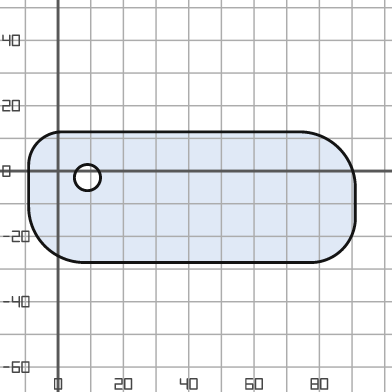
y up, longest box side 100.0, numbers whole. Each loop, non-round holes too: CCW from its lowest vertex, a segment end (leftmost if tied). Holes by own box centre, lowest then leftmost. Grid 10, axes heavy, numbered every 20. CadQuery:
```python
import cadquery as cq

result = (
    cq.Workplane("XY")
    .moveTo(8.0, -28.0)
    .lineTo(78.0, -28.0)
    .threePointArc((87.0, -24.0), (91.0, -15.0))
    .lineTo(91.0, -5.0)
    .threePointArc((86.0, 7.0), (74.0, 12.0))
    .lineTo(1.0, 12.0)
    .threePointArc((-6.0, 9.0), (-9.0, 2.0))
    .lineTo(-9.0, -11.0)
    .threePointArc((-4.0, -23.0), (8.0, -28.0))
    .close()
    .moveTo(9.0, -2.0)
    .circle(4.0)
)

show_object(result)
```